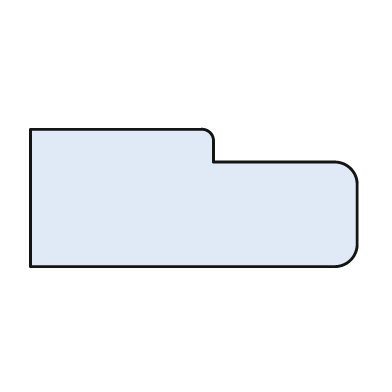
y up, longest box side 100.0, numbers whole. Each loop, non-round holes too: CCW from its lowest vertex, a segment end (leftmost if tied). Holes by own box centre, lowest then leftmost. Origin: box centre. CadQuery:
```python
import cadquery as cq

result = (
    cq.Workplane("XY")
    .moveTo(-50.0, -21.0)
    .lineTo(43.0, -21.0)
    .threePointArc((48.0, -19.0), (50.0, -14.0))
    .lineTo(50.0, 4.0)
    .threePointArc((48.0, 9.0), (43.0, 11.0))
    .lineTo(6.0, 11.0)
    .lineTo(6.0, 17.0)
    .threePointArc((5.0, 20.0), (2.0, 21.0))
    .lineTo(-50.0, 21.0)
    .close()
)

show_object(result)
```